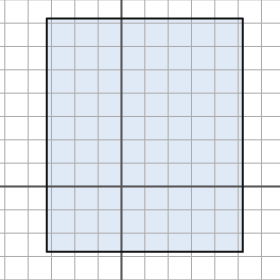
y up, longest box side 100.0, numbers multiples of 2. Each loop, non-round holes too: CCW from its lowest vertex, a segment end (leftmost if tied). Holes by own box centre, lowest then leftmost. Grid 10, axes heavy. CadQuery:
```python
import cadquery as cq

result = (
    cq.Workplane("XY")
    .moveTo(-32.0, -28.0)
    .lineTo(52.0, -28.0)
    .lineTo(52.0, 72.0)
    .lineTo(-32.0, 72.0)
    .close()
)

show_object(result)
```